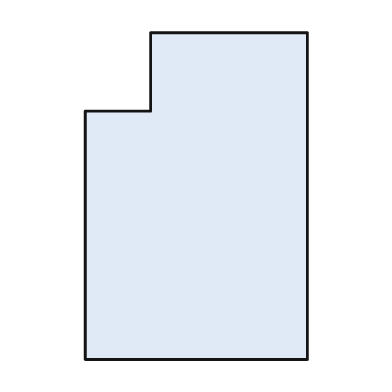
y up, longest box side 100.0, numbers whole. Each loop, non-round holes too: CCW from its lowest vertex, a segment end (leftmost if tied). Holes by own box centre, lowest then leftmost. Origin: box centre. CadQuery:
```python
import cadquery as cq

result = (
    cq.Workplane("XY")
    .moveTo(-34.0, -50.0)
    .lineTo(34.0, -50.0)
    .lineTo(34.0, 50.0)
    .lineTo(-14.0, 50.0)
    .lineTo(-14.0, 26.0)
    .lineTo(-34.0, 26.0)
    .close()
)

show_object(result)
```